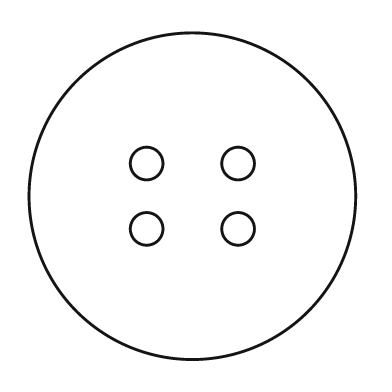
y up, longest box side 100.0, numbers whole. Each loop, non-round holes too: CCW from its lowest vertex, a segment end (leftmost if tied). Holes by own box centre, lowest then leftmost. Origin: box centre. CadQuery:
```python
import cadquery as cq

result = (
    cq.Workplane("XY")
    .moveTo(0.0, 0.0)
    .circle(50.0)
    .moveTo(-14.0, -10.0)
    .circle(5.0)
    .moveTo(14.0, -10.0)
    .circle(5.0)
    .moveTo(-14.0, 10.0)
    .circle(5.0)
    .moveTo(14.0, 10.0)
    .circle(5.0)
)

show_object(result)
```